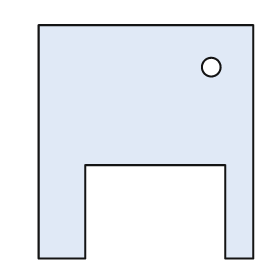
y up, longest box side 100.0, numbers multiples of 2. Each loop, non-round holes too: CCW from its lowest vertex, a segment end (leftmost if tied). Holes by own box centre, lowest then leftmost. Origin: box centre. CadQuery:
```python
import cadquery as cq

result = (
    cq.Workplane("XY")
    .moveTo(-46.0, -50.0)
    .lineTo(-26.0, -50.0)
    .lineTo(-26.0, -10.0)
    .lineTo(34.0, -10.0)
    .lineTo(34.0, -50.0)
    .lineTo(46.0, -50.0)
    .lineTo(46.0, 50.0)
    .lineTo(-46.0, 50.0)
    .close()
    .moveTo(28.0, 32.0)
    .circle(4.0)
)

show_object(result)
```